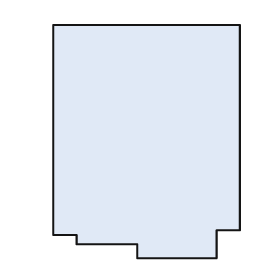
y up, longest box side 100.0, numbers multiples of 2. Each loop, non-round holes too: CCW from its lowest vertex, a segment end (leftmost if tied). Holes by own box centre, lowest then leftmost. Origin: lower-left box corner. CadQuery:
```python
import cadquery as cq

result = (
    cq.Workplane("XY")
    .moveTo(36.0, 0.0)
    .lineTo(70.0, 0.0)
    .lineTo(70.0, 12.0)
    .lineTo(80.0, 12.0)
    .lineTo(80.0, 100.0)
    .lineTo(0.0, 100.0)
    .lineTo(0.0, 10.0)
    .lineTo(10.0, 10.0)
    .lineTo(10.0, 6.0)
    .lineTo(36.0, 6.0)
    .close()
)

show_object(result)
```